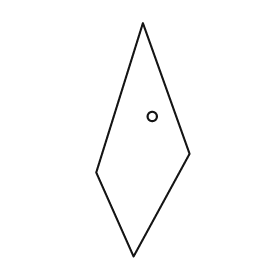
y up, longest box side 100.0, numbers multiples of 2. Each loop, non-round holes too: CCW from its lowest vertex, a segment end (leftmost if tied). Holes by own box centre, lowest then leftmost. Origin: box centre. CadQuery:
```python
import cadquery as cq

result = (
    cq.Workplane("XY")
    .moveTo(-4.0, -50.0)
    .lineTo(20.0, -6.0)
    .lineTo(0.0, 50.0)
    .lineTo(-20.0, -14.0)
    .close()
    .moveTo(4.0, 10.0)
    .circle(2.0)
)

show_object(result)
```